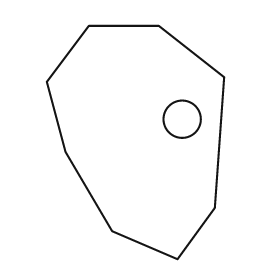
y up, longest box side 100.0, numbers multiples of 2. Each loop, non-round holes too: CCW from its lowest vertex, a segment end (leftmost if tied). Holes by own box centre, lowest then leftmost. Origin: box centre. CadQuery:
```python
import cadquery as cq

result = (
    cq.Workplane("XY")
    .moveTo(18.0, -50.0)
    .lineTo(34.0, -28.0)
    .lineTo(38.0, 28.0)
    .lineTo(10.0, 50.0)
    .lineTo(-20.0, 50.0)
    .lineTo(-38.0, 26.0)
    .lineTo(-30.0, -4.0)
    .lineTo(-10.0, -38.0)
    .close()
    .moveTo(20.0, 10.0)
    .circle(8.0)
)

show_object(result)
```